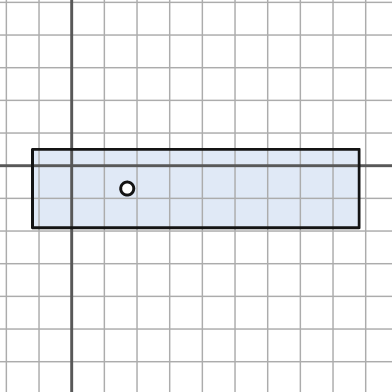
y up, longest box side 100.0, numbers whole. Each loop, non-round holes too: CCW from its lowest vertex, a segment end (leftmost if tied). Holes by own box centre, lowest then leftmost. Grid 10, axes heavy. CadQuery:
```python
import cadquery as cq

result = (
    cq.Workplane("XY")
    .moveTo(-12.0, -19.0)
    .lineTo(88.0, -19.0)
    .lineTo(88.0, 5.0)
    .lineTo(-12.0, 5.0)
    .close()
    .moveTo(17.0, -7.0)
    .circle(2.0)
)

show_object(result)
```